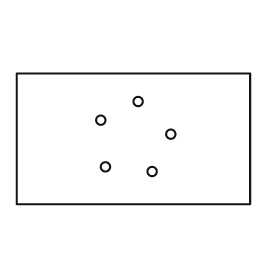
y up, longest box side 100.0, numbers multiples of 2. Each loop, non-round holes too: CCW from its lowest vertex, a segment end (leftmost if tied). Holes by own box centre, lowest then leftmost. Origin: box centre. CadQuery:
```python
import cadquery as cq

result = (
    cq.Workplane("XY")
    .moveTo(-50.0, -28.0)
    .lineTo(50.0, -28.0)
    .lineTo(50.0, 28.0)
    .lineTo(-50.0, 28.0)
    .close()
    .moveTo(8.0, -14.0)
    .circle(2.0)
    .moveTo(-12.0, -12.0)
    .circle(2.0)
    .moveTo(16.0, 2.0)
    .circle(2.0)
    .moveTo(-14.0, 8.0)
    .circle(2.0)
    .moveTo(2.0, 16.0)
    .circle(2.0)
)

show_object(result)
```